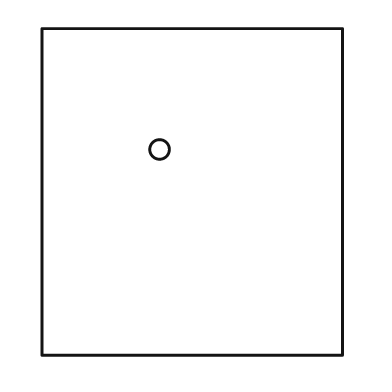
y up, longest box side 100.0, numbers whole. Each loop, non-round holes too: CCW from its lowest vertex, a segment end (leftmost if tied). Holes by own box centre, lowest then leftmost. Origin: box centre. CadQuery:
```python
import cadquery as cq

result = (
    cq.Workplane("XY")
    .moveTo(-46.0, -50.0)
    .lineTo(46.0, -50.0)
    .lineTo(46.0, 50.0)
    .lineTo(-46.0, 50.0)
    .close()
    .moveTo(-10.0, 13.0)
    .circle(3.0)
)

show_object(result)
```